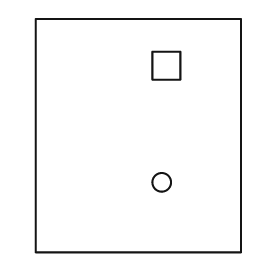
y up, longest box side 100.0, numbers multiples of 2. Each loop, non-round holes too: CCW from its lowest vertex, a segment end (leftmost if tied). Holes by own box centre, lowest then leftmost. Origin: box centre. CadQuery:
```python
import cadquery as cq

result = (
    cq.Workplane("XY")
    .moveTo(-44.0, -50.0)
    .lineTo(44.0, -50.0)
    .lineTo(44.0, 50.0)
    .lineTo(-44.0, 50.0)
    .close()
    .moveTo(10.0, -20.0)
    .circle(4.0)
    .moveTo(6.0, 24.0)
    .lineTo(18.0, 24.0)
    .lineTo(18.0, 36.0)
    .lineTo(6.0, 36.0)
    .close()
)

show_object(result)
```